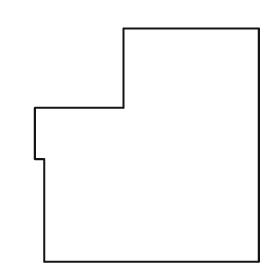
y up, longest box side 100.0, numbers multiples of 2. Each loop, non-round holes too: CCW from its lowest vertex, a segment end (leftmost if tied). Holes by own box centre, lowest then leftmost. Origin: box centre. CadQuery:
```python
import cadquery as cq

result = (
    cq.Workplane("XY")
    .moveTo(-44.0, -50.0)
    .lineTo(48.0, -50.0)
    .lineTo(48.0, 50.0)
    .lineTo(-10.0, 50.0)
    .lineTo(-10.0, 16.0)
    .lineTo(-48.0, 16.0)
    .lineTo(-48.0, -6.0)
    .lineTo(-44.0, -6.0)
    .close()
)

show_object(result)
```